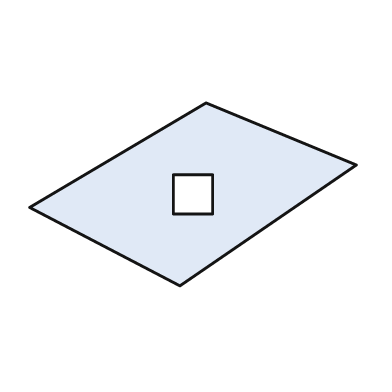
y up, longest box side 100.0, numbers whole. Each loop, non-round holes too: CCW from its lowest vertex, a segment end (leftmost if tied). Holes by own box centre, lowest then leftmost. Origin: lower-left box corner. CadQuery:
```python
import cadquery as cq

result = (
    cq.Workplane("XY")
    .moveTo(46.0, 0.0)
    .lineTo(100.0, 37.0)
    .lineTo(54.0, 56.0)
    .lineTo(0.0, 24.0)
    .close()
    .moveTo(44.0, 22.0)
    .lineTo(56.0, 22.0)
    .lineTo(56.0, 34.0)
    .lineTo(44.0, 34.0)
    .close()
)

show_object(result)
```